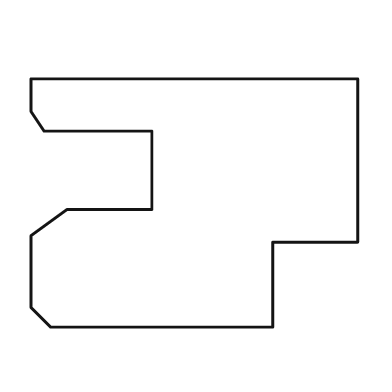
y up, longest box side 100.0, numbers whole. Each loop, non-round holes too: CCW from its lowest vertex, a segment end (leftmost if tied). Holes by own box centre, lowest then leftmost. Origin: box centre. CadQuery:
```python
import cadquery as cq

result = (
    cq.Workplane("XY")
    .moveTo(-44.0, -38.0)
    .lineTo(24.0, -38.0)
    .lineTo(24.0, -12.0)
    .lineTo(50.0, -12.0)
    .lineTo(50.0, 38.0)
    .lineTo(-50.0, 38.0)
    .lineTo(-50.0, 28.0)
    .lineTo(-46.0, 22.0)
    .lineTo(-13.0, 22.0)
    .lineTo(-13.0, -2.0)
    .lineTo(-39.0, -2.0)
    .lineTo(-50.0, -10.0)
    .lineTo(-50.0, -32.0)
    .close()
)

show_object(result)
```